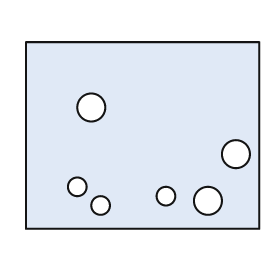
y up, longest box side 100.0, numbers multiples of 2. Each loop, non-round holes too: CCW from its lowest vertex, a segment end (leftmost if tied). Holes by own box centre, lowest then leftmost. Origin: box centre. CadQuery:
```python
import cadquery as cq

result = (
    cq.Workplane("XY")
    .moveTo(-50.0, -40.0)
    .lineTo(50.0, -40.0)
    .lineTo(50.0, 40.0)
    .lineTo(-50.0, 40.0)
    .close()
    .moveTo(-18.0, -30.0)
    .circle(4.0)
    .moveTo(28.0, -28.0)
    .circle(6.0)
    .moveTo(10.0, -26.0)
    .circle(4.0)
    .moveTo(-28.0, -22.0)
    .circle(4.0)
    .moveTo(40.0, -8.0)
    .circle(6.0)
    .moveTo(-22.0, 12.0)
    .circle(6.0)
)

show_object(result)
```